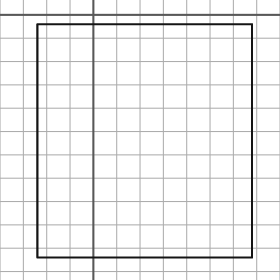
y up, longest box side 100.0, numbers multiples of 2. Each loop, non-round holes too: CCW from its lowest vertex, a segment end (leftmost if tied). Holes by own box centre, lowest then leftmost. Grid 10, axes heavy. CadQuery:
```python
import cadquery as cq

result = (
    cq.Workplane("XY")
    .moveTo(-24.0, -104.0)
    .lineTo(68.0, -104.0)
    .lineTo(68.0, -4.0)
    .lineTo(-24.0, -4.0)
    .close()
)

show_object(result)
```